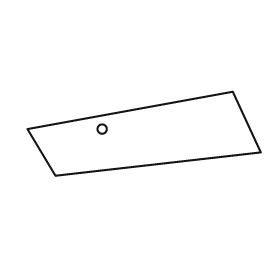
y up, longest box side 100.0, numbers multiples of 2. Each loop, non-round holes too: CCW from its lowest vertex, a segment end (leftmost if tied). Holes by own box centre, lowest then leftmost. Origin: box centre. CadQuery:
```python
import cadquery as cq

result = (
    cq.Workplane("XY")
    .moveTo(-38.0, -18.0)
    .lineTo(50.0, -8.0)
    .lineTo(38.0, 18.0)
    .lineTo(-50.0, 2.0)
    .close()
    .moveTo(-18.0, 2.0)
    .circle(2.0)
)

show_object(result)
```